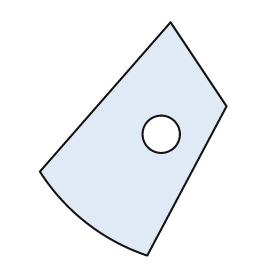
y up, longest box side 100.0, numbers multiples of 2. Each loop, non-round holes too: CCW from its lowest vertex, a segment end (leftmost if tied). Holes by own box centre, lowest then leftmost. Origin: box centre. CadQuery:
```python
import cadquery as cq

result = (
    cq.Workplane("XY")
    .moveTo(6.0, -50.0)
    .lineTo(40.0, 14.0)
    .lineTo(16.0, 50.0)
    .lineTo(-40.0, -14.0)
    .threePointArc((-20.0, -36.0), (6.0, -50.0))
    .close()
    .moveTo(12.0, 2.0)
    .circle(8.0)
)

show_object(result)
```